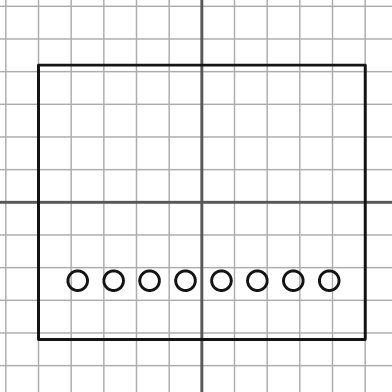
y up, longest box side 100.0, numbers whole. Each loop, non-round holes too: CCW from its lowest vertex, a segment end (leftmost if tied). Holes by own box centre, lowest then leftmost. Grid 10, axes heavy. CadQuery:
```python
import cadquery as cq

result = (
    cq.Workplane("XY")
    .moveTo(-50.0, -42.0)
    .lineTo(50.0, -42.0)
    .lineTo(50.0, 42.0)
    .lineTo(-50.0, 42.0)
    .close()
    .moveTo(-38.0, -24.0)
    .circle(3.0)
    .moveTo(-27.0, -24.0)
    .circle(3.0)
    .moveTo(-16.0, -24.0)
    .circle(3.0)
    .moveTo(-5.0, -24.0)
    .circle(3.0)
    .moveTo(6.0, -24.0)
    .circle(3.0)
    .moveTo(17.0, -24.0)
    .circle(3.0)
    .moveTo(28.0, -24.0)
    .circle(3.0)
    .moveTo(39.0, -24.0)
    .circle(3.0)
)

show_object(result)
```